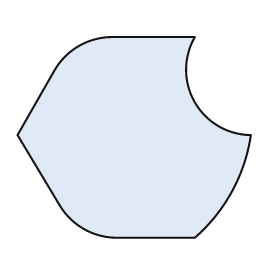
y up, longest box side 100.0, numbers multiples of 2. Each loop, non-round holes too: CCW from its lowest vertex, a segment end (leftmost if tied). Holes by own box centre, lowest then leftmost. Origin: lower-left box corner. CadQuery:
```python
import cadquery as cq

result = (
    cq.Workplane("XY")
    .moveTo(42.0, 0.0)
    .lineTo(76.0, 0.0)
    .threePointArc((92.0, 20.0), (100.0, 44.0))
    .threePointArc((76.0, 58.0), (76.0, 86.0))
    .lineTo(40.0, 86.0)
    .threePointArc((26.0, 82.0), (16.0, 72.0))
    .lineTo(0.0, 44.0)
    .lineTo(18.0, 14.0)
    .threePointArc((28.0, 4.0), (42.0, 0.0))
    .close()
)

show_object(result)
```